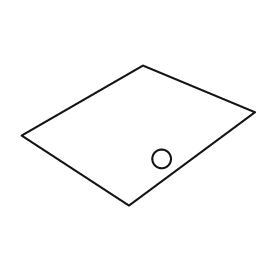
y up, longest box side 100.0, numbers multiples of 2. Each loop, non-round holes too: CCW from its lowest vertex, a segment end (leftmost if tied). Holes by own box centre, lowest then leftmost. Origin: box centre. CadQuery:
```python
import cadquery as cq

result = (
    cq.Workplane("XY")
    .moveTo(-4.0, -30.0)
    .lineTo(50.0, 10.0)
    .lineTo(2.0, 30.0)
    .lineTo(-50.0, 0.0)
    .close()
    .moveTo(10.0, -10.0)
    .circle(4.0)
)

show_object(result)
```